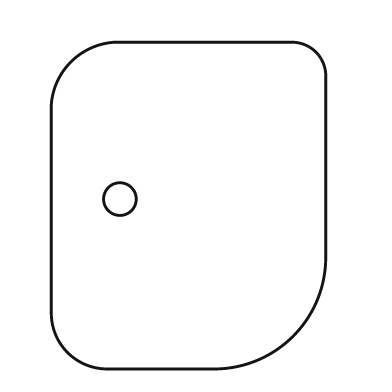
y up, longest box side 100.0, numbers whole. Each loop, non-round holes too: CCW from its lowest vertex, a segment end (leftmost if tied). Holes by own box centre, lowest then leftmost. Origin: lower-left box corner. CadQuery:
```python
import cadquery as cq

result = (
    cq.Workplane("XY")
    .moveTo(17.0, 0.0)
    .lineTo(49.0, 0.0)
    .threePointArc((74.0, 10.0), (84.0, 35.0))
    .lineTo(84.0, 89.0)
    .threePointArc((81.0, 97.0), (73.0, 100.0))
    .lineTo(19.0, 100.0)
    .threePointArc((6.0, 94.0), (0.0, 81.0))
    .lineTo(0.0, 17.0)
    .threePointArc((5.0, 5.0), (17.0, 0.0))
    .close()
    .moveTo(21.0, 52.0)
    .circle(5.0)
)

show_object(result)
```